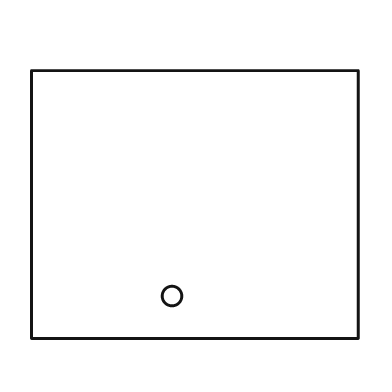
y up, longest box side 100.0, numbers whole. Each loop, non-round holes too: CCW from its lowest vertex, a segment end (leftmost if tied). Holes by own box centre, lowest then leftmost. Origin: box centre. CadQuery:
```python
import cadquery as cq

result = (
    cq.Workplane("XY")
    .moveTo(-50.0, -41.0)
    .lineTo(50.0, -41.0)
    .lineTo(50.0, 41.0)
    .lineTo(-50.0, 41.0)
    .close()
    .moveTo(-7.0, -28.0)
    .circle(3.0)
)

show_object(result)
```